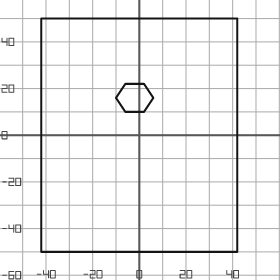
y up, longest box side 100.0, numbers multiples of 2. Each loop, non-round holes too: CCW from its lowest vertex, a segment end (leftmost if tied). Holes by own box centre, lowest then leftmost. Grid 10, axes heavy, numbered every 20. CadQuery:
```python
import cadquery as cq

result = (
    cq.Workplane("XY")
    .moveTo(-42.0, -50.0)
    .lineTo(42.0, -50.0)
    .lineTo(42.0, 50.0)
    .lineTo(-42.0, 50.0)
    .close()
    .moveTo(-6.0, 10.0)
    .lineTo(2.0, 10.0)
    .lineTo(6.0, 16.0)
    .lineTo(2.0, 22.0)
    .lineTo(-6.0, 22.0)
    .lineTo(-10.0, 16.0)
    .close()
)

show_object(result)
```